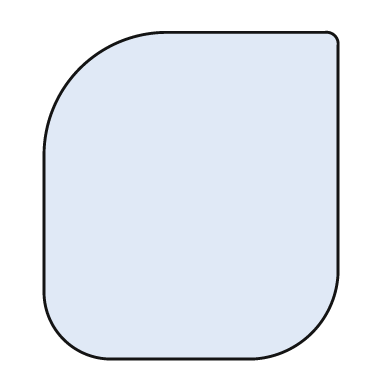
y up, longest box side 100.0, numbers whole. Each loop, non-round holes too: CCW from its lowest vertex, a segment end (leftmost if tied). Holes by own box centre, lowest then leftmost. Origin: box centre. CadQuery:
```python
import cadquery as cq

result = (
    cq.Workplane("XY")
    .moveTo(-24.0, -50.0)
    .lineTo(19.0, -50.0)
    .threePointArc((37.0, -42.0), (45.0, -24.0))
    .lineTo(45.0, 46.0)
    .threePointArc((44.0, 49.0), (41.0, 50.0))
    .lineTo(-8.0, 50.0)
    .threePointArc((-34.0, 39.0), (-45.0, 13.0))
    .lineTo(-45.0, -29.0)
    .threePointArc((-39.0, -44.0), (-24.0, -50.0))
    .close()
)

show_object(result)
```